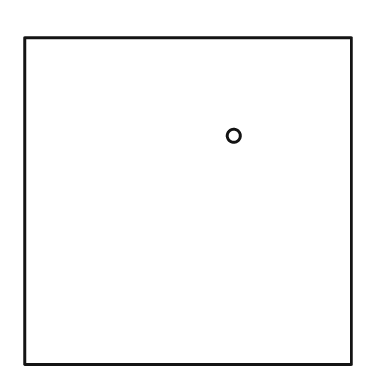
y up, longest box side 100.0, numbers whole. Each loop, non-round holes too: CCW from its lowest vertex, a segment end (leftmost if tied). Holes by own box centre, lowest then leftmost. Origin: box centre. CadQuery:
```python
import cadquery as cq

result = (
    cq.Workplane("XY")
    .moveTo(-50.0, -50.0)
    .lineTo(50.0, -50.0)
    .lineTo(50.0, 50.0)
    .lineTo(-50.0, 50.0)
    .close()
    .moveTo(14.0, 20.0)
    .circle(2.0)
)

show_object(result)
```